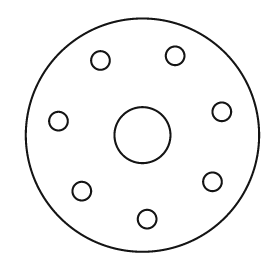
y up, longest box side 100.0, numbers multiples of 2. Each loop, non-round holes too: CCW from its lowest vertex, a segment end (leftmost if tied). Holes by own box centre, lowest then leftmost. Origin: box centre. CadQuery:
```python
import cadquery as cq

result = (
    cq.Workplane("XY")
    .moveTo(0.0, 0.0)
    .circle(50.0)
    .moveTo(2.0, -36.0)
    .circle(4.0)
    .moveTo(-26.0, -24.0)
    .circle(4.0)
    .moveTo(30.0, -20.0)
    .circle(4.0)
    .moveTo(0.0, 0.0)
    .circle(12.0)
    .moveTo(-36.0, 6.0)
    .circle(4.0)
    .moveTo(34.0, 10.0)
    .circle(4.0)
    .moveTo(-18.0, 32.0)
    .circle(4.0)
    .moveTo(14.0, 34.0)
    .circle(4.0)
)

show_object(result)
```